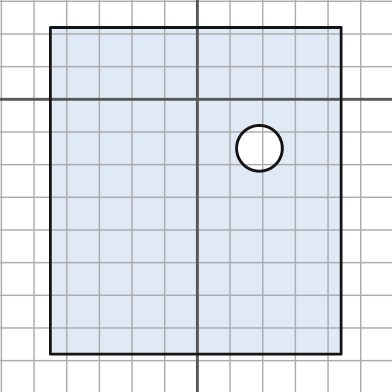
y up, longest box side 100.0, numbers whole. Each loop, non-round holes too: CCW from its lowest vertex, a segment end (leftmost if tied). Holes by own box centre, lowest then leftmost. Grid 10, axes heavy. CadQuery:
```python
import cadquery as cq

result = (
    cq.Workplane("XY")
    .moveTo(-45.0, -78.0)
    .lineTo(44.0, -78.0)
    .lineTo(44.0, 22.0)
    .lineTo(-45.0, 22.0)
    .close()
    .moveTo(19.0, -15.0)
    .circle(7.0)
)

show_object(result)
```